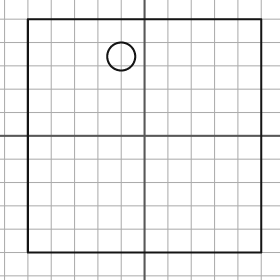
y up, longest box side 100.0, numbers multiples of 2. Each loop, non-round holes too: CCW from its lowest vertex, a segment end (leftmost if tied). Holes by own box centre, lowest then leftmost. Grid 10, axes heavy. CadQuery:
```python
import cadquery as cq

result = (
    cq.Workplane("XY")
    .moveTo(-50.0, -50.0)
    .lineTo(50.0, -50.0)
    .lineTo(50.0, 50.0)
    .lineTo(-50.0, 50.0)
    .close()
    .moveTo(-10.0, 34.0)
    .circle(6.0)
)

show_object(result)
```